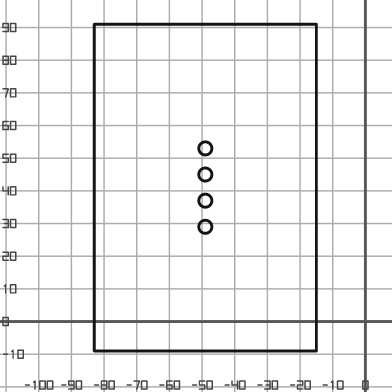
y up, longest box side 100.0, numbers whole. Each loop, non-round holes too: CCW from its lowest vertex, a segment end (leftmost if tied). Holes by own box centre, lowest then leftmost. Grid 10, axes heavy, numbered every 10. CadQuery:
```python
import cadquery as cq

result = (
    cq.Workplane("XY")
    .moveTo(-83.0, -9.0)
    .lineTo(-15.0, -9.0)
    .lineTo(-15.0, 91.0)
    .lineTo(-83.0, 91.0)
    .close()
    .moveTo(-49.0, 29.0)
    .circle(2.0)
    .moveTo(-49.0, 37.0)
    .circle(2.0)
    .moveTo(-49.0, 45.0)
    .circle(2.0)
    .moveTo(-49.0, 53.0)
    .circle(2.0)
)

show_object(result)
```